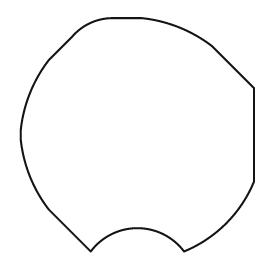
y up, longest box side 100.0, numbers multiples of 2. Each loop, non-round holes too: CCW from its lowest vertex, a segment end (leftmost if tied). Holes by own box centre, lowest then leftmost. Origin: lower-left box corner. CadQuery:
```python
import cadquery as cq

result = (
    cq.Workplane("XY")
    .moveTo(30.0, 0.0)
    .threePointArc((50.0, 10.0), (70.0, 0.0))
    .threePointArc((88.0, 12.0), (100.0, 30.0))
    .lineTo(100.0, 70.0)
    .lineTo(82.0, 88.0)
    .threePointArc((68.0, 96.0), (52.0, 100.0))
    .lineTo(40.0, 100.0)
    .threePointArc((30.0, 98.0), (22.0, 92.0))
    .lineTo(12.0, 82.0)
    .threePointArc((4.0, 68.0), (0.0, 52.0))
    .lineTo(0.0, 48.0)
    .threePointArc((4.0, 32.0), (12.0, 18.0))
    .close()
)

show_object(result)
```